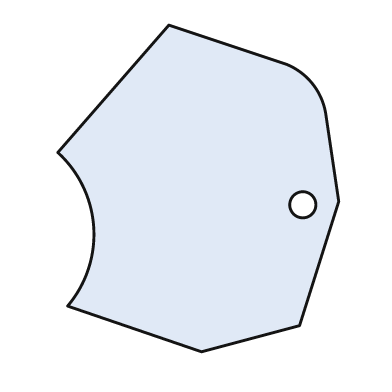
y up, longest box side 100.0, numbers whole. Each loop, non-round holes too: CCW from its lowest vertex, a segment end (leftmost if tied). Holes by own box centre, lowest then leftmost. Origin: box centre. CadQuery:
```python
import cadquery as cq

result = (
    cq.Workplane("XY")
    .moveTo(1.0, -50.0)
    .lineTo(31.0, -42.0)
    .lineTo(43.0, -4.0)
    .lineTo(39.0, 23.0)
    .threePointArc((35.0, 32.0), (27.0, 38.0))
    .lineTo(-9.0, 50.0)
    .lineTo(-43.0, 11.0)
    .threePointArc((-32.0, -12.0), (-40.0, -36.0))
    .close()
    .moveTo(32.0, -5.0)
    .circle(4.0)
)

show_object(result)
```